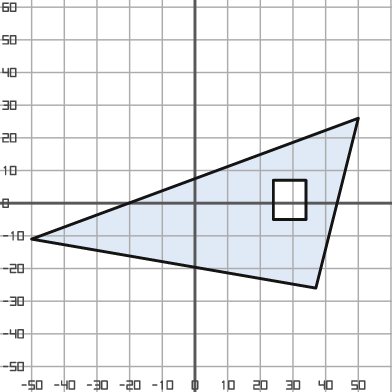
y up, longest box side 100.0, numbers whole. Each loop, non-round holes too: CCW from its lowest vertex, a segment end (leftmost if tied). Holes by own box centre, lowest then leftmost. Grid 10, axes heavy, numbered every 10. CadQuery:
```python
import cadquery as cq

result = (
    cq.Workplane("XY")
    .moveTo(37.0, -26.0)
    .lineTo(50.0, 26.0)
    .lineTo(-50.0, -11.0)
    .close()
    .moveTo(24.0, -5.0)
    .lineTo(34.0, -5.0)
    .lineTo(34.0, 7.0)
    .lineTo(24.0, 7.0)
    .close()
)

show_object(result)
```